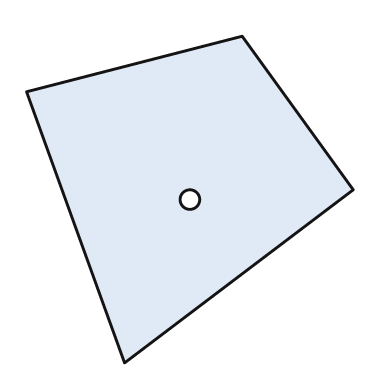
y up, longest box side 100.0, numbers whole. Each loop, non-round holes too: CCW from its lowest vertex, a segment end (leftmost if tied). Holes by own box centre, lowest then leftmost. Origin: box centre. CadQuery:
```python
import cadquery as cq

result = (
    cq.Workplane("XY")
    .moveTo(-20.0, -50.0)
    .lineTo(50.0, 3.0)
    .lineTo(16.0, 50.0)
    .lineTo(-50.0, 33.0)
    .close()
    .moveTo(0.0, 0.0)
    .circle(3.0)
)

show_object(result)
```